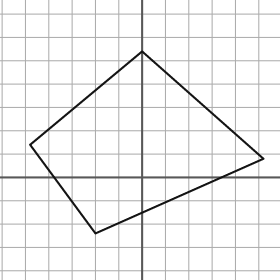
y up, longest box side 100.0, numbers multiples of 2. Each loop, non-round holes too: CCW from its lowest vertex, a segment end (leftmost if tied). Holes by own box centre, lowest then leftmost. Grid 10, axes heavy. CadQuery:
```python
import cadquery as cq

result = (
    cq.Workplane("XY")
    .moveTo(-20.0, -24.0)
    .lineTo(52.0, 8.0)
    .lineTo(0.0, 54.0)
    .lineTo(-48.0, 14.0)
    .close()
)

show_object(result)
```